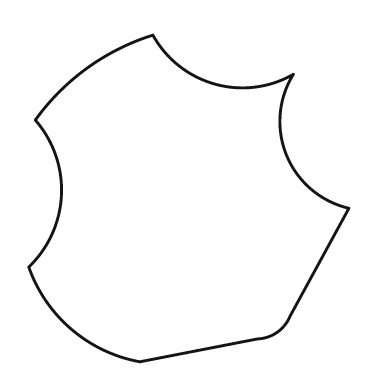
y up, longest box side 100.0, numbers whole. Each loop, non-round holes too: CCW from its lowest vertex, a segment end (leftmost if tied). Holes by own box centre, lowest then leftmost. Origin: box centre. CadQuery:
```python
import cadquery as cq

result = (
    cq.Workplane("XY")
    .moveTo(-15.0, -50.0)
    .lineTo(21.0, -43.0)
    .threePointArc((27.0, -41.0), (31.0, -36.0))
    .lineTo(49.0, -3.0)
    .threePointArc((30.0, 13.0), (32.0, 38.0))
    .threePointArc((8.0, 35.0), (-11.0, 50.0))
    .threePointArc((-31.0, 40.0), (-47.0, 24.0))
    .threePointArc((-39.0, 1.0), (-49.0, -21.0))
    .threePointArc((-36.0, -40.0), (-15.0, -50.0))
    .close()
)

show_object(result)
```